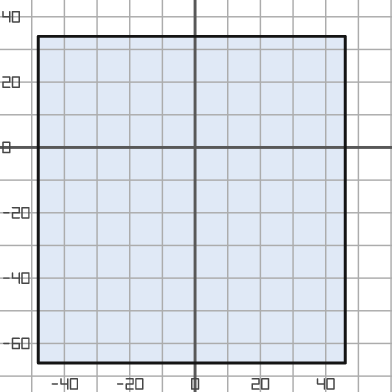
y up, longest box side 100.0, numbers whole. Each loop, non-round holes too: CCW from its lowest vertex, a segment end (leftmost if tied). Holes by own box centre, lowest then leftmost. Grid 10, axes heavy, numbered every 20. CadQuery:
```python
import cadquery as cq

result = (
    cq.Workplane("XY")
    .moveTo(-48.0, -66.0)
    .lineTo(46.0, -66.0)
    .lineTo(46.0, 34.0)
    .lineTo(-48.0, 34.0)
    .close()
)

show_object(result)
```